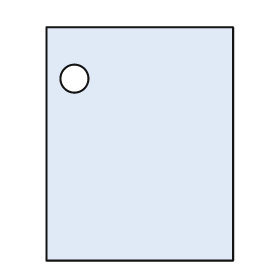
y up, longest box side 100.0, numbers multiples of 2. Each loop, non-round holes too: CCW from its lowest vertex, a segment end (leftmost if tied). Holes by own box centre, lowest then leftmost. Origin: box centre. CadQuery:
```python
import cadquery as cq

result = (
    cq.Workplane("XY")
    .moveTo(-40.0, -50.0)
    .lineTo(40.0, -50.0)
    .lineTo(40.0, 50.0)
    .lineTo(-40.0, 50.0)
    .close()
    .moveTo(-28.0, 28.0)
    .circle(6.0)
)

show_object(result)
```